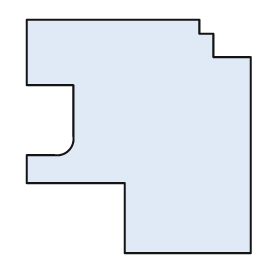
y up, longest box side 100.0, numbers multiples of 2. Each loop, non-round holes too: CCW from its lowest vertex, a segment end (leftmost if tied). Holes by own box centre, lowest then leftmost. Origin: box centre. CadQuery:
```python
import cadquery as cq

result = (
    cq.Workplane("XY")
    .moveTo(-6.0, -50.0)
    .lineTo(48.0, -50.0)
    .lineTo(48.0, 34.0)
    .lineTo(32.0, 34.0)
    .lineTo(32.0, 44.0)
    .lineTo(26.0, 44.0)
    .lineTo(26.0, 50.0)
    .lineTo(-48.0, 50.0)
    .lineTo(-48.0, 22.0)
    .lineTo(-28.0, 22.0)
    .lineTo(-28.0, 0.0)
    .threePointArc((-30.0, -6.0), (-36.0, -8.0))
    .lineTo(-48.0, -8.0)
    .lineTo(-48.0, -20.0)
    .lineTo(-6.0, -20.0)
    .close()
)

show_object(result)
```